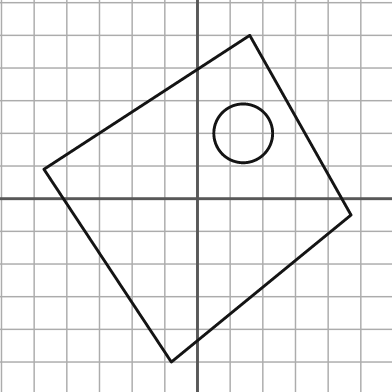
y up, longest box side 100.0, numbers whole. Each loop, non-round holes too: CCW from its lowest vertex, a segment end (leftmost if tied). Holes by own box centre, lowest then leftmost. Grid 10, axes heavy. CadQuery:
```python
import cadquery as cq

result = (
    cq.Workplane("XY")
    .moveTo(-8.0, -50.0)
    .lineTo(47.0, -5.0)
    .lineTo(16.0, 50.0)
    .lineTo(-47.0, 9.0)
    .close()
    .moveTo(14.0, 20.0)
    .circle(9.0)
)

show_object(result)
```